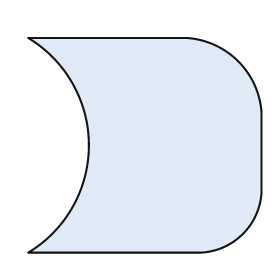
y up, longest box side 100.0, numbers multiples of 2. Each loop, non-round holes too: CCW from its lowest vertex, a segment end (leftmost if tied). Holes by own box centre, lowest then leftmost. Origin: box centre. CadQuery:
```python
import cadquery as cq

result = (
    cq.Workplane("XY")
    .moveTo(-50.0, -46.0)
    .lineTo(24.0, -46.0)
    .threePointArc((42.0, -38.0), (50.0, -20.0))
    .lineTo(50.0, 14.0)
    .threePointArc((40.0, 36.0), (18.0, 46.0))
    .lineTo(-50.0, 46.0)
    .threePointArc((-24.0, 0.0), (-50.0, -46.0))
    .close()
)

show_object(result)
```